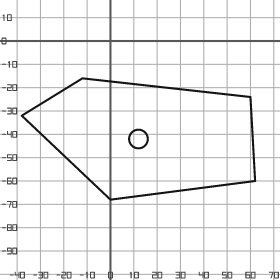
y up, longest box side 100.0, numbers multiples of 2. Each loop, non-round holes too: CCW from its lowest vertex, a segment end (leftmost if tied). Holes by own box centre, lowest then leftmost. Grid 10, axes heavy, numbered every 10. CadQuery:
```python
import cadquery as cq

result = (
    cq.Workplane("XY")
    .moveTo(0.0, -68.0)
    .lineTo(62.0, -60.0)
    .lineTo(60.0, -24.0)
    .lineTo(-12.0, -16.0)
    .lineTo(-38.0, -32.0)
    .close()
    .moveTo(12.0, -42.0)
    .circle(4.0)
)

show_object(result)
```